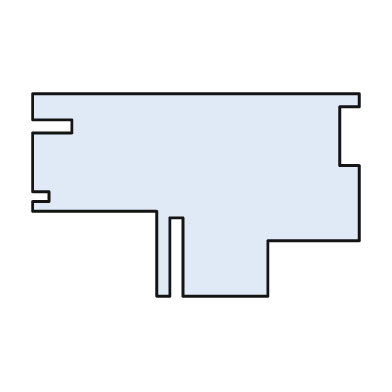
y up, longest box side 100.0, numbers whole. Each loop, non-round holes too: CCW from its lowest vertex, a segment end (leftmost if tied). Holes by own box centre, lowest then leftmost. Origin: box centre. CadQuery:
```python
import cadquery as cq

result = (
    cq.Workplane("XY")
    .moveTo(-12.0, -31.0)
    .lineTo(-8.0, -31.0)
    .lineTo(-8.0, -7.0)
    .lineTo(-4.0, -7.0)
    .lineTo(-4.0, -31.0)
    .lineTo(22.0, -31.0)
    .lineTo(22.0, -14.0)
    .lineTo(50.0, -14.0)
    .lineTo(50.0, 9.0)
    .lineTo(44.0, 9.0)
    .lineTo(44.0, 27.0)
    .lineTo(50.0, 27.0)
    .lineTo(50.0, 31.0)
    .lineTo(-50.0, 31.0)
    .lineTo(-50.0, 23.0)
    .lineTo(-38.0, 23.0)
    .lineTo(-38.0, 19.0)
    .lineTo(-50.0, 19.0)
    .lineTo(-50.0, 1.0)
    .lineTo(-45.0, 1.0)
    .lineTo(-45.0, -2.0)
    .lineTo(-50.0, -2.0)
    .lineTo(-50.0, -5.0)
    .lineTo(-12.0, -5.0)
    .close()
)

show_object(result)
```